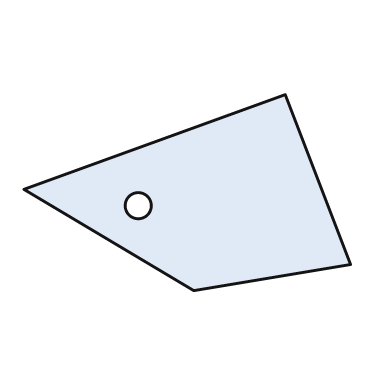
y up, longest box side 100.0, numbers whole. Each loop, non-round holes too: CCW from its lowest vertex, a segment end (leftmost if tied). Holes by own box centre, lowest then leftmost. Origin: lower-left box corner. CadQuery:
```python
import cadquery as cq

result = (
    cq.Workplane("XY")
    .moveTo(52.0, 0.0)
    .lineTo(100.0, 8.0)
    .lineTo(80.0, 60.0)
    .lineTo(0.0, 31.0)
    .close()
    .moveTo(35.0, 26.0)
    .circle(4.0)
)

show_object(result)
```